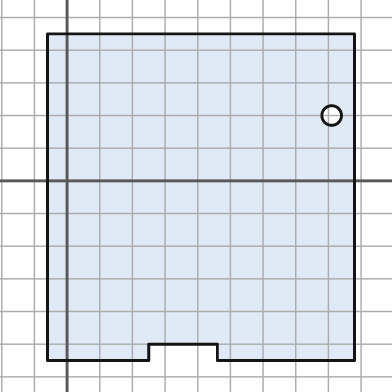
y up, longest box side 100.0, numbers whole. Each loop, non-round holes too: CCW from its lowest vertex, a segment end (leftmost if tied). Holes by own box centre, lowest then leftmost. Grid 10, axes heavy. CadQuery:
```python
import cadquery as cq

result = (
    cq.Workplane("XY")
    .moveTo(-6.0, -55.0)
    .lineTo(25.0, -55.0)
    .lineTo(25.0, -50.0)
    .lineTo(46.0, -50.0)
    .lineTo(46.0, -55.0)
    .lineTo(88.0, -55.0)
    .lineTo(88.0, 45.0)
    .lineTo(-6.0, 45.0)
    .close()
    .moveTo(81.0, 20.0)
    .circle(3.0)
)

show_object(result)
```